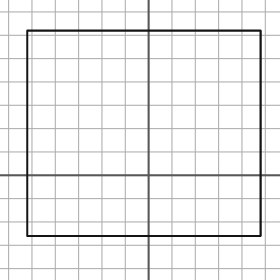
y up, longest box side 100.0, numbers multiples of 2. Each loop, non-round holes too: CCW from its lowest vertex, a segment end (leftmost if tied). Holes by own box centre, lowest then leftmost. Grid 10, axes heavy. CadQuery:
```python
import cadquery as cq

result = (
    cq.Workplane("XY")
    .moveTo(-52.0, -26.0)
    .lineTo(48.0, -26.0)
    .lineTo(48.0, 62.0)
    .lineTo(-52.0, 62.0)
    .close()
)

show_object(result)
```